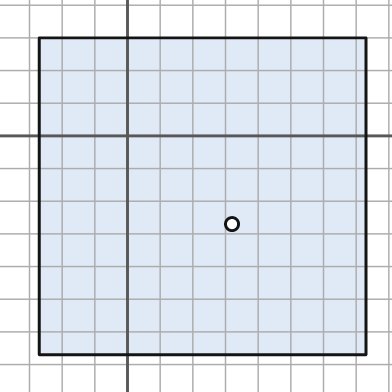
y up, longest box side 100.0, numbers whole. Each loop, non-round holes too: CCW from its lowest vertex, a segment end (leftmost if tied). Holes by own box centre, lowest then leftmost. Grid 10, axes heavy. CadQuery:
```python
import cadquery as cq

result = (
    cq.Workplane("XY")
    .moveTo(-27.0, -67.0)
    .lineTo(73.0, -67.0)
    .lineTo(73.0, 30.0)
    .lineTo(-27.0, 30.0)
    .close()
    .moveTo(32.0, -27.0)
    .circle(2.0)
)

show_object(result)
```